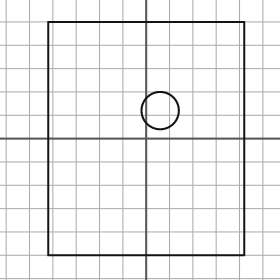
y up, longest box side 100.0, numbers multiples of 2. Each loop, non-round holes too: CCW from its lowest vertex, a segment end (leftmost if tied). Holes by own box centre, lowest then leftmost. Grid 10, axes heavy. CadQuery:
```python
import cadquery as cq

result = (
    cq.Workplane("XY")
    .moveTo(-42.0, -50.0)
    .lineTo(42.0, -50.0)
    .lineTo(42.0, 50.0)
    .lineTo(-42.0, 50.0)
    .close()
    .moveTo(6.0, 12.0)
    .circle(8.0)
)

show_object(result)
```